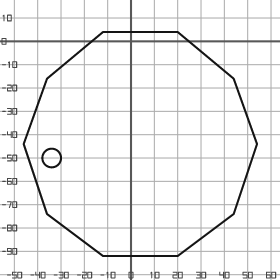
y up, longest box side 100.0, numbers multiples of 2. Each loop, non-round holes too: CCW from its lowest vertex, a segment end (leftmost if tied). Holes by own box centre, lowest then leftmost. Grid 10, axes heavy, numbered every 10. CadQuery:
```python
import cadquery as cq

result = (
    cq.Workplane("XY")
    .moveTo(-12.0, -92.0)
    .lineTo(20.0, -92.0)
    .lineTo(44.0, -74.0)
    .lineTo(54.0, -44.0)
    .lineTo(44.0, -16.0)
    .lineTo(20.0, 4.0)
    .lineTo(-12.0, 4.0)
    .lineTo(-36.0, -16.0)
    .lineTo(-46.0, -44.0)
    .lineTo(-36.0, -74.0)
    .close()
    .moveTo(-34.0, -50.0)
    .circle(4.0)
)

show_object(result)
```